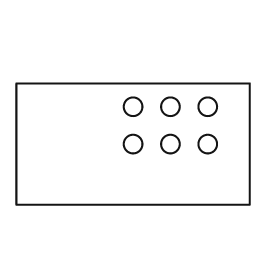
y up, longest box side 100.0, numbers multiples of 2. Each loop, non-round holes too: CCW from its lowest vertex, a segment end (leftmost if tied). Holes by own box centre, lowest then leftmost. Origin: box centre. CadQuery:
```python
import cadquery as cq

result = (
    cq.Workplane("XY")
    .moveTo(-50.0, -26.0)
    .lineTo(50.0, -26.0)
    .lineTo(50.0, 26.0)
    .lineTo(-50.0, 26.0)
    .close()
    .moveTo(0.0, 0.0)
    .circle(4.0)
    .moveTo(16.0, 0.0)
    .circle(4.0)
    .moveTo(32.0, 0.0)
    .circle(4.0)
    .moveTo(0.0, 16.0)
    .circle(4.0)
    .moveTo(16.0, 16.0)
    .circle(4.0)
    .moveTo(32.0, 16.0)
    .circle(4.0)
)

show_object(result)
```